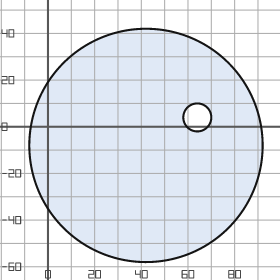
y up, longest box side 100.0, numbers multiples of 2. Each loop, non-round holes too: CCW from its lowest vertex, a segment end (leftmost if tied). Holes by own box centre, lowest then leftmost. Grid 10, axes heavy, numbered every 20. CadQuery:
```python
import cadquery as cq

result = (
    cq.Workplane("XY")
    .moveTo(42.0, -8.0)
    .circle(50.0)
    .moveTo(64.0, 4.0)
    .circle(6.0)
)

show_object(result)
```